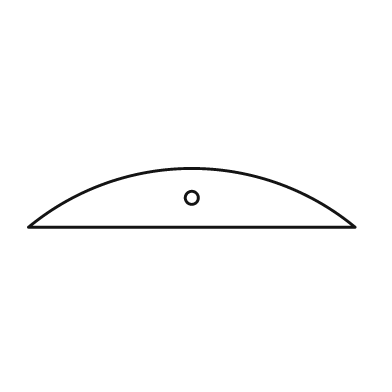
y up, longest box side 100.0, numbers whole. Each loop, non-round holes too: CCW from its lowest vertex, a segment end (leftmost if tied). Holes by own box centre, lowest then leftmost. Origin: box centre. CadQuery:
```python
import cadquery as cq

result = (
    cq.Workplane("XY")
    .moveTo(-50.0, -9.0)
    .lineTo(50.0, -9.0)
    .threePointArc((0.0, 9.0), (-50.0, -9.0))
    .close()
    .moveTo(0.0, 0.0)
    .circle(2.0)
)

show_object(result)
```